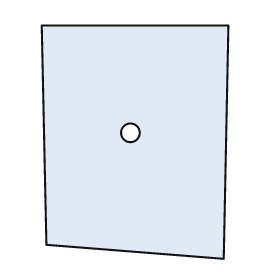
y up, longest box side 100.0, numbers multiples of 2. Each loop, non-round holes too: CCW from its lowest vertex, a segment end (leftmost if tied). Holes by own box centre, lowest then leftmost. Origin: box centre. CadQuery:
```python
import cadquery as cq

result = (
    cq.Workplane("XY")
    .moveTo(38.0, -50.0)
    .lineTo(40.0, 50.0)
    .lineTo(-40.0, 50.0)
    .lineTo(-38.0, -44.0)
    .close()
    .moveTo(-2.0, 4.0)
    .circle(4.0)
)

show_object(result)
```